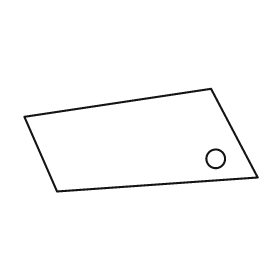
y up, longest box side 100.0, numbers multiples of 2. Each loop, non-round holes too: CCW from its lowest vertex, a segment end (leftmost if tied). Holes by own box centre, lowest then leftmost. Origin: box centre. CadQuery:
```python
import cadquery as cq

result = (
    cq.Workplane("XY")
    .moveTo(-36.0, -22.0)
    .lineTo(50.0, -16.0)
    .lineTo(30.0, 22.0)
    .lineTo(-50.0, 10.0)
    .close()
    .moveTo(32.0, -8.0)
    .circle(4.0)
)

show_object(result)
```